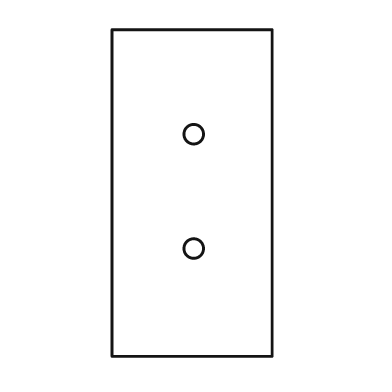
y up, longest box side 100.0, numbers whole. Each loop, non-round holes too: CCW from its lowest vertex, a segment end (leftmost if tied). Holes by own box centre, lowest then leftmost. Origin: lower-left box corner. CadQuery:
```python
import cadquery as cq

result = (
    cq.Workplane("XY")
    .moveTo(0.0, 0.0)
    .lineTo(49.0, 0.0)
    .lineTo(49.0, 100.0)
    .lineTo(0.0, 100.0)
    .close()
    .moveTo(25.0, 33.0)
    .circle(3.0)
    .moveTo(25.0, 68.0)
    .circle(3.0)
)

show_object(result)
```